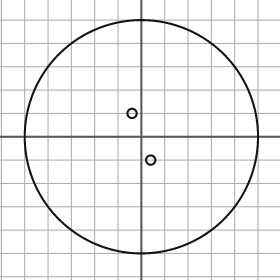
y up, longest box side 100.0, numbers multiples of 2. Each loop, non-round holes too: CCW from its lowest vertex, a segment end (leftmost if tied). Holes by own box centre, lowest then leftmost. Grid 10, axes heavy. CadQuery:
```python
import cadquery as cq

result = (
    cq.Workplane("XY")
    .moveTo(0.0, 0.0)
    .circle(50.0)
    .moveTo(4.0, -10.0)
    .circle(2.0)
    .moveTo(-4.0, 10.0)
    .circle(2.0)
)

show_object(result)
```